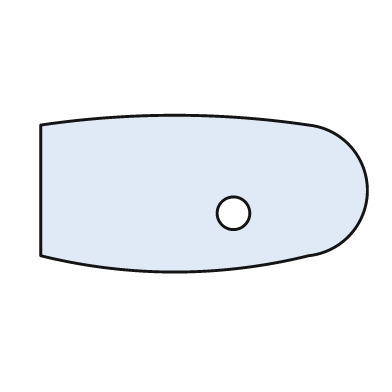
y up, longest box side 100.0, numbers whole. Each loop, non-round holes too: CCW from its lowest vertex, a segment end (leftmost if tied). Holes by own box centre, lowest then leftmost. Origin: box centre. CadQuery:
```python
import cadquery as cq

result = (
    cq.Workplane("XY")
    .moveTo(-50.0, -19.0)
    .threePointArc((-9.0, -24.0), (32.0, -19.0))
    .threePointArc((50.0, 1.0), (32.0, 21.0))
    .threePointArc((-9.0, 24.0), (-50.0, 21.0))
    .close()
    .moveTo(9.0, -6.0)
    .circle(5.0)
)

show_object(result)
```